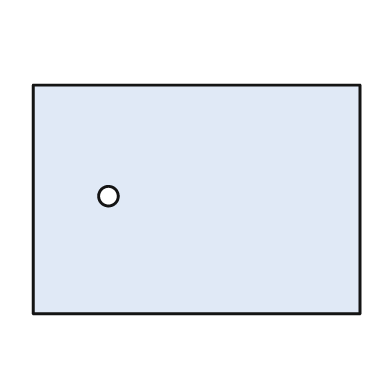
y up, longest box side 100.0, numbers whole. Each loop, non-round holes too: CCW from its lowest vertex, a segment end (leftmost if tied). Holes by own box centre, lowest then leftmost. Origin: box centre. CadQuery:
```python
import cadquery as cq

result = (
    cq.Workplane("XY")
    .moveTo(-50.0, -35.0)
    .lineTo(50.0, -35.0)
    .lineTo(50.0, 35.0)
    .lineTo(-50.0, 35.0)
    .close()
    .moveTo(-27.0, 1.0)
    .circle(3.0)
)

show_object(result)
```